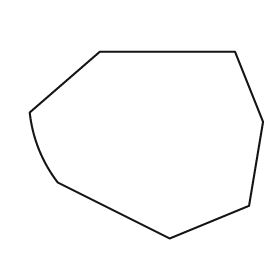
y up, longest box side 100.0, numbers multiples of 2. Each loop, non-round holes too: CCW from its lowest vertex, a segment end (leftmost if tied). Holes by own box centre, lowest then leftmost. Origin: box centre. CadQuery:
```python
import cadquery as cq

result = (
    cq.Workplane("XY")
    .moveTo(10.0, -40.0)
    .lineTo(44.0, -26.0)
    .lineTo(50.0, 10.0)
    .lineTo(38.0, 40.0)
    .lineTo(-20.0, 40.0)
    .lineTo(-50.0, 14.0)
    .threePointArc((-46.0, -2.0), (-38.0, -16.0))
    .close()
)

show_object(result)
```